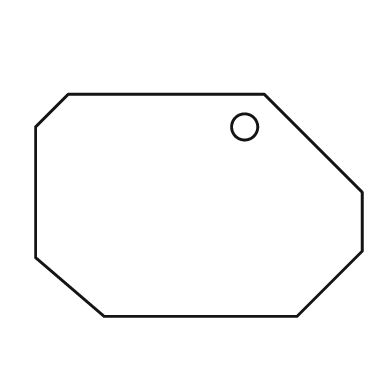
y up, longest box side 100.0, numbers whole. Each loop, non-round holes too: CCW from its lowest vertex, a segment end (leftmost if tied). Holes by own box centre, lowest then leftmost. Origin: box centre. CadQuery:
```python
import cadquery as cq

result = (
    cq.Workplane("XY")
    .moveTo(-29.0, -34.0)
    .lineTo(30.0, -34.0)
    .lineTo(50.0, -14.0)
    .lineTo(50.0, 4.0)
    .lineTo(20.0, 34.0)
    .lineTo(-40.0, 34.0)
    .lineTo(-50.0, 24.0)
    .lineTo(-50.0, -16.0)
    .close()
    .moveTo(14.0, 24.0)
    .circle(4.0)
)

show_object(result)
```